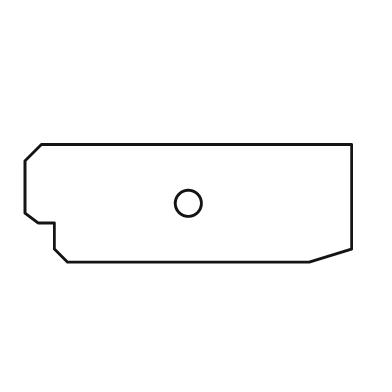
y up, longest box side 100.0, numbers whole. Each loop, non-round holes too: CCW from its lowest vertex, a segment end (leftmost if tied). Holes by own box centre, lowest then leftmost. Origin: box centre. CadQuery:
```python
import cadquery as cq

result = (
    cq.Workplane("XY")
    .moveTo(-37.0, -18.0)
    .lineTo(37.0, -18.0)
    .lineTo(50.0, -14.0)
    .lineTo(50.0, 18.0)
    .lineTo(-45.0, 18.0)
    .lineTo(-50.0, 13.0)
    .lineTo(-50.0, -3.0)
    .lineTo(-46.0, -6.0)
    .lineTo(-41.0, -6.0)
    .lineTo(-41.0, -14.0)
    .close()
    .moveTo(0.0, 0.0)
    .circle(4.0)
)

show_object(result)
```